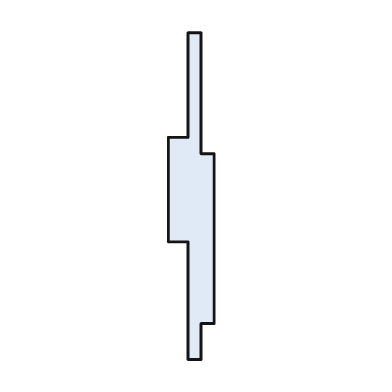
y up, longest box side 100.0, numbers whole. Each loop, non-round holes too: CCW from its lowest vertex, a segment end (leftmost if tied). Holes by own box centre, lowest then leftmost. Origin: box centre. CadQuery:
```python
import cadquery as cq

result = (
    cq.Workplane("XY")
    .moveTo(-1.0, -50.0)
    .lineTo(3.0, -50.0)
    .lineTo(3.0, -39.0)
    .lineTo(7.0, -39.0)
    .lineTo(7.0, 13.0)
    .lineTo(3.0, 13.0)
    .lineTo(3.0, 50.0)
    .lineTo(-1.0, 50.0)
    .lineTo(-1.0, 18.0)
    .lineTo(-7.0, 18.0)
    .lineTo(-7.0, -14.0)
    .lineTo(-1.0, -14.0)
    .close()
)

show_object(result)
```